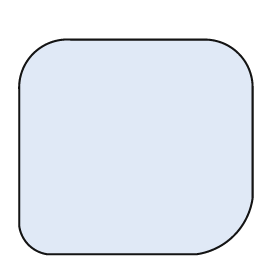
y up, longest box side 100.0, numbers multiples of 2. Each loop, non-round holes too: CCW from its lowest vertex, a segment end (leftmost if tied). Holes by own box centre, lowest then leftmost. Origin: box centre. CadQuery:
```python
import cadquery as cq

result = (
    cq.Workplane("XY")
    .moveTo(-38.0, -46.0)
    .lineTo(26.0, -46.0)
    .threePointArc((42.0, -38.0), (50.0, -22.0))
    .lineTo(50.0, 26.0)
    .threePointArc((44.0, 40.0), (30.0, 46.0))
    .lineTo(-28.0, 46.0)
    .threePointArc((-44.0, 40.0), (-50.0, 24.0))
    .lineTo(-50.0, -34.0)
    .threePointArc((-46.0, -42.0), (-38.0, -46.0))
    .close()
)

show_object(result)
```